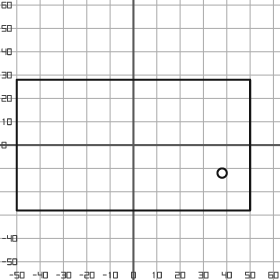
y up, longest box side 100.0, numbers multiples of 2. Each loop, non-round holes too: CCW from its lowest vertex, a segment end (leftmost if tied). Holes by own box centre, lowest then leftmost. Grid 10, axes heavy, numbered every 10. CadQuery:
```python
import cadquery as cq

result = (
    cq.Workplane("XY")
    .moveTo(-50.0, -28.0)
    .lineTo(50.0, -28.0)
    .lineTo(50.0, 28.0)
    .lineTo(-50.0, 28.0)
    .close()
    .moveTo(38.0, -12.0)
    .circle(2.0)
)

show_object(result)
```